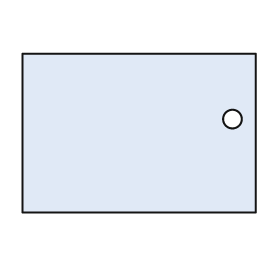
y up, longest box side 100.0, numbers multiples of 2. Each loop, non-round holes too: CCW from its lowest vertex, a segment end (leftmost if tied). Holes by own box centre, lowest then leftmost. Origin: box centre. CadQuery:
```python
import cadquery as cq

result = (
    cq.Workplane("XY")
    .moveTo(-50.0, -34.0)
    .lineTo(50.0, -34.0)
    .lineTo(50.0, 34.0)
    .lineTo(-50.0, 34.0)
    .close()
    .moveTo(40.0, 6.0)
    .circle(4.0)
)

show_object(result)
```